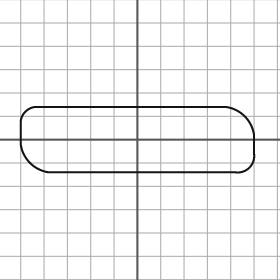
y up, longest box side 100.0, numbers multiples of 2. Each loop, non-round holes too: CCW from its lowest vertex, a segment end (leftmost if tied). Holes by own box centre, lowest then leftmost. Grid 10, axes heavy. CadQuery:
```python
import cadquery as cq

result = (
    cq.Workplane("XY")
    .moveTo(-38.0, -14.0)
    .lineTo(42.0, -14.0)
    .threePointArc((48.0, -12.0), (50.0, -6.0))
    .lineTo(50.0, 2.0)
    .threePointArc((46.0, 10.0), (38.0, 14.0))
    .lineTo(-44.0, 14.0)
    .threePointArc((-48.0, 12.0), (-50.0, 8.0))
    .lineTo(-50.0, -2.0)
    .threePointArc((-46.0, -10.0), (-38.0, -14.0))
    .close()
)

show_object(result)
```